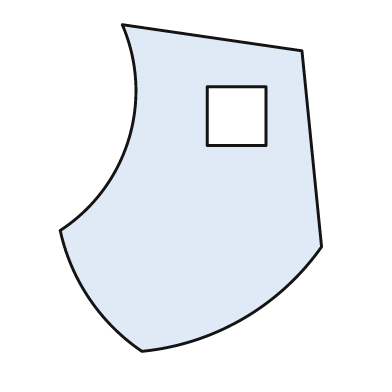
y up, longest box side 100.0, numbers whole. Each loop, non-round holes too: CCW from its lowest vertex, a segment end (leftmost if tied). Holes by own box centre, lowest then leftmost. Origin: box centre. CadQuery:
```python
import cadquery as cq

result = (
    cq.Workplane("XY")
    .moveTo(-15.0, -50.0)
    .threePointArc((16.0, -40.0), (40.0, -18.0))
    .lineTo(34.0, 42.0)
    .lineTo(-21.0, 50.0)
    .threePointArc((-19.0, 15.0), (-40.0, -13.0))
    .threePointArc((-31.0, -34.0), (-15.0, -50.0))
    .close()
    .moveTo(5.0, 13.0)
    .lineTo(23.0, 13.0)
    .lineTo(23.0, 31.0)
    .lineTo(5.0, 31.0)
    .close()
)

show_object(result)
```